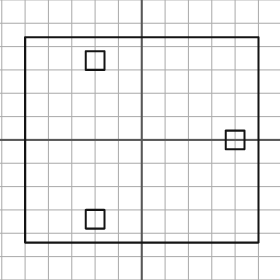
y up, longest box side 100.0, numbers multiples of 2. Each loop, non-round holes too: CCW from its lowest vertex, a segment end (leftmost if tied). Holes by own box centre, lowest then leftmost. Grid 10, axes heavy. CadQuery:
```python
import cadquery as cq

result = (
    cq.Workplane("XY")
    .moveTo(-50.0, -44.0)
    .lineTo(50.0, -44.0)
    .lineTo(50.0, 44.0)
    .lineTo(-50.0, 44.0)
    .close()
    .moveTo(-24.0, -38.0)
    .lineTo(-16.0, -38.0)
    .lineTo(-16.0, -30.0)
    .lineTo(-24.0, -30.0)
    .close()
    .moveTo(36.0, -4.0)
    .lineTo(44.0, -4.0)
    .lineTo(44.0, 4.0)
    .lineTo(36.0, 4.0)
    .close()
    .moveTo(-24.0, 30.0)
    .lineTo(-16.0, 30.0)
    .lineTo(-16.0, 38.0)
    .lineTo(-24.0, 38.0)
    .close()
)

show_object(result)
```